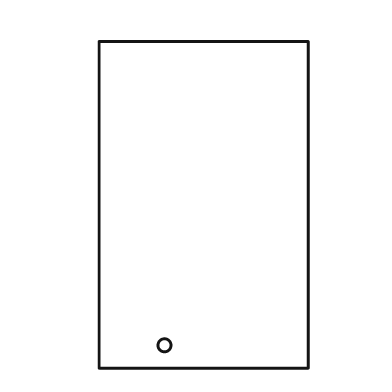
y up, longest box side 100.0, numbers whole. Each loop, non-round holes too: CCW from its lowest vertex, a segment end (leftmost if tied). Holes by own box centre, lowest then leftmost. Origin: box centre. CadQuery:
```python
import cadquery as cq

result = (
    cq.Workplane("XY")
    .moveTo(-32.0, -50.0)
    .lineTo(32.0, -50.0)
    .lineTo(32.0, 50.0)
    .lineTo(-32.0, 50.0)
    .close()
    .moveTo(-12.0, -43.0)
    .circle(2.0)
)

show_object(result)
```